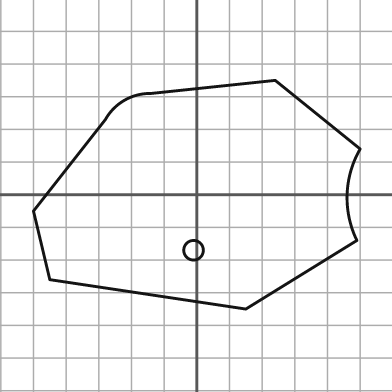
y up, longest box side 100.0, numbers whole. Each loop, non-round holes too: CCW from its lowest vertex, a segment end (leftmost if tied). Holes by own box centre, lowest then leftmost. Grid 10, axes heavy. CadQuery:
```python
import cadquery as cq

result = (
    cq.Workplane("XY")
    .moveTo(15.0, -35.0)
    .lineTo(49.0, -14.0)
    .threePointArc((46.0, 0.0), (50.0, 14.0))
    .lineTo(24.0, 35.0)
    .lineTo(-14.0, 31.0)
    .threePointArc((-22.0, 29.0), (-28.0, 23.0))
    .lineTo(-50.0, -5.0)
    .lineTo(-45.0, -26.0)
    .close()
    .moveTo(-1.0, -17.0)
    .circle(3.0)
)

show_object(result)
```